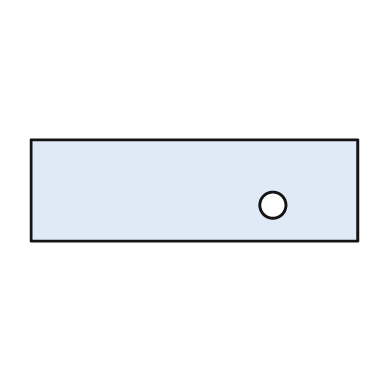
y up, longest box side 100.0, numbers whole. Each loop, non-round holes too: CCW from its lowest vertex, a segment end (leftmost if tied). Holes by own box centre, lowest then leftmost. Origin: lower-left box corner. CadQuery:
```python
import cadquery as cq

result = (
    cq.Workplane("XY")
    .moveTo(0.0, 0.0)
    .lineTo(100.0, 0.0)
    .lineTo(100.0, 31.0)
    .lineTo(0.0, 31.0)
    .close()
    .moveTo(74.0, 11.0)
    .circle(4.0)
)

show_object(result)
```